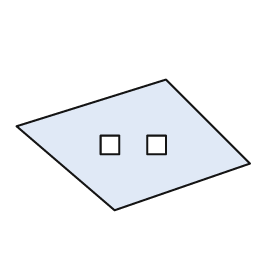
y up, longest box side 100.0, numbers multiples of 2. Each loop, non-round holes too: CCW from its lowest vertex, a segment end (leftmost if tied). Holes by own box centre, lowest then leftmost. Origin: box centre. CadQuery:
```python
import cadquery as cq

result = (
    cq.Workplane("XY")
    .moveTo(-8.0, -28.0)
    .lineTo(50.0, -8.0)
    .lineTo(14.0, 28.0)
    .lineTo(-50.0, 8.0)
    .close()
    .moveTo(-14.0, -4.0)
    .lineTo(-6.0, -4.0)
    .lineTo(-6.0, 4.0)
    .lineTo(-14.0, 4.0)
    .close()
    .moveTo(6.0, -4.0)
    .lineTo(14.0, -4.0)
    .lineTo(14.0, 4.0)
    .lineTo(6.0, 4.0)
    .close()
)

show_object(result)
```